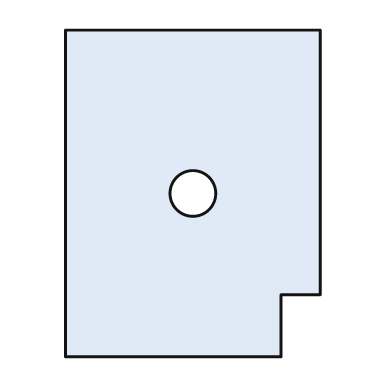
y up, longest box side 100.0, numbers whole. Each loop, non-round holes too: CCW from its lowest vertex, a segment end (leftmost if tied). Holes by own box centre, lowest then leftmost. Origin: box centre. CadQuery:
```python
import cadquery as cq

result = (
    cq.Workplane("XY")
    .moveTo(-39.0, -50.0)
    .lineTo(27.0, -50.0)
    .lineTo(27.0, -31.0)
    .lineTo(39.0, -31.0)
    .lineTo(39.0, 50.0)
    .lineTo(-39.0, 50.0)
    .close()
    .moveTo(0.0, 0.0)
    .circle(7.0)
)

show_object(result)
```